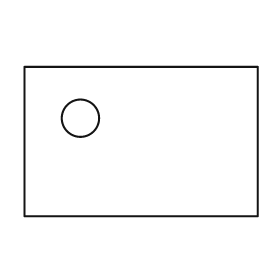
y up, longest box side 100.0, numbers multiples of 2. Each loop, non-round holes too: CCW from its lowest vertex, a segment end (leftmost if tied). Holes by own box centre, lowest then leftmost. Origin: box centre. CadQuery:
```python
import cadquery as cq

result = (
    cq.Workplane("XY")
    .moveTo(-50.0, -32.0)
    .lineTo(50.0, -32.0)
    .lineTo(50.0, 32.0)
    .lineTo(-50.0, 32.0)
    .close()
    .moveTo(-26.0, 10.0)
    .circle(8.0)
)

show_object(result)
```